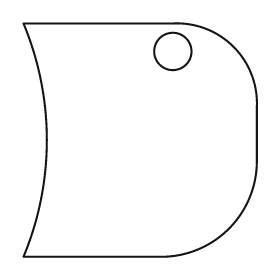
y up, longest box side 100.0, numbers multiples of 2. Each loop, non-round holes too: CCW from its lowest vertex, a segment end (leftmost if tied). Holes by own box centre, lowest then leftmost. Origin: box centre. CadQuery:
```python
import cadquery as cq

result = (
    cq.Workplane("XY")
    .moveTo(-50.0, -50.0)
    .lineTo(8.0, -50.0)
    .threePointArc((38.0, -38.0), (50.0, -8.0))
    .lineTo(50.0, 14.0)
    .threePointArc((40.0, 40.0), (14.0, 50.0))
    .lineTo(-50.0, 50.0)
    .threePointArc((-40.0, 0.0), (-50.0, -50.0))
    .close()
    .moveTo(14.0, 38.0)
    .circle(8.0)
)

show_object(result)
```